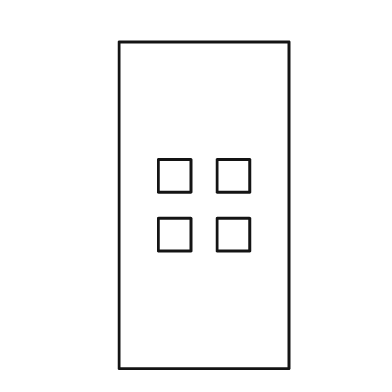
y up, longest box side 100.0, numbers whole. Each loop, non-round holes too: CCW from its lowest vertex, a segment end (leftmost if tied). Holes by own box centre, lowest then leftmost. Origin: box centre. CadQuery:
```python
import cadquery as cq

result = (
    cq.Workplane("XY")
    .moveTo(-26.0, -50.0)
    .lineTo(26.0, -50.0)
    .lineTo(26.0, 50.0)
    .lineTo(-26.0, 50.0)
    .close()
    .moveTo(-14.0, -14.0)
    .lineTo(-4.0, -14.0)
    .lineTo(-4.0, -4.0)
    .lineTo(-14.0, -4.0)
    .close()
    .moveTo(4.0, -14.0)
    .lineTo(14.0, -14.0)
    .lineTo(14.0, -4.0)
    .lineTo(4.0, -4.0)
    .close()
    .moveTo(-14.0, 4.0)
    .lineTo(-4.0, 4.0)
    .lineTo(-4.0, 14.0)
    .lineTo(-14.0, 14.0)
    .close()
    .moveTo(4.0, 4.0)
    .lineTo(14.0, 4.0)
    .lineTo(14.0, 14.0)
    .lineTo(4.0, 14.0)
    .close()
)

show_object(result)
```